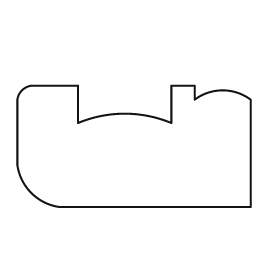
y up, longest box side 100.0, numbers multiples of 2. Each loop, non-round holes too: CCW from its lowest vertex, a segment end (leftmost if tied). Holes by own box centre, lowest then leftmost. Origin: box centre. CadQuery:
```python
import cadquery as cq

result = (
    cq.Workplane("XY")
    .moveTo(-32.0, -26.0)
    .lineTo(50.0, -26.0)
    .lineTo(50.0, 20.0)
    .threePointArc((38.0, 24.0), (26.0, 20.0))
    .lineTo(26.0, 26.0)
    .lineTo(16.0, 26.0)
    .lineTo(16.0, 10.0)
    .threePointArc((-4.0, 14.0), (-24.0, 10.0))
    .lineTo(-24.0, 26.0)
    .lineTo(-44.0, 26.0)
    .threePointArc((-48.0, 24.0), (-50.0, 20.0))
    .lineTo(-50.0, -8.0)
    .threePointArc((-44.0, -20.0), (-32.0, -26.0))
    .close()
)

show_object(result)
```